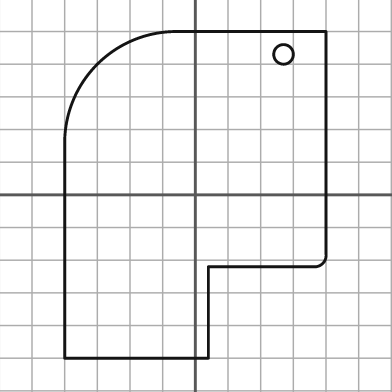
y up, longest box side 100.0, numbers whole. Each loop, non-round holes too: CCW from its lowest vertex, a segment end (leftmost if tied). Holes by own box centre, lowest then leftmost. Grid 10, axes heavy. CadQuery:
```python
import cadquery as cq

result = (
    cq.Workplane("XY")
    .moveTo(-40.0, -50.0)
    .lineTo(4.0, -50.0)
    .lineTo(4.0, -22.0)
    .lineTo(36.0, -22.0)
    .threePointArc((39.0, -21.0), (40.0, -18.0))
    .lineTo(40.0, 50.0)
    .lineTo(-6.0, 50.0)
    .threePointArc((-30.0, 40.0), (-40.0, 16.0))
    .close()
    .moveTo(27.0, 43.0)
    .circle(3.0)
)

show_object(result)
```